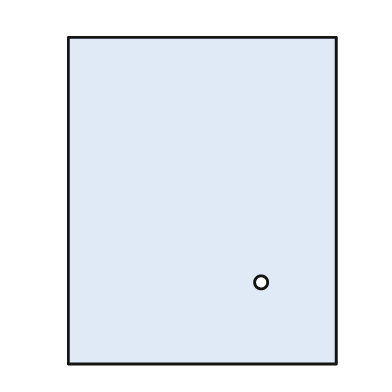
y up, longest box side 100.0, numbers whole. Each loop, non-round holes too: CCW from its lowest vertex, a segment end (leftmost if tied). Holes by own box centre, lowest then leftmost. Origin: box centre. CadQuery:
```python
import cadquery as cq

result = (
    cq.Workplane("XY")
    .moveTo(-41.0, -50.0)
    .lineTo(41.0, -50.0)
    .lineTo(41.0, 50.0)
    .lineTo(-41.0, 50.0)
    .close()
    .moveTo(18.0, -25.0)
    .circle(2.0)
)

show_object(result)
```